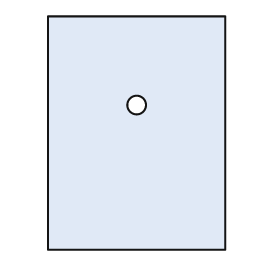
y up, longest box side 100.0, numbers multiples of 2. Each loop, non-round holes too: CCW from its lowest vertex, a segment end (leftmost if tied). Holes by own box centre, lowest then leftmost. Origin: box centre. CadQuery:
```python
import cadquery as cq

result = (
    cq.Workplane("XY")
    .moveTo(-38.0, -50.0)
    .lineTo(38.0, -50.0)
    .lineTo(38.0, 50.0)
    .lineTo(-38.0, 50.0)
    .close()
    .moveTo(0.0, 12.0)
    .circle(4.0)
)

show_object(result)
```